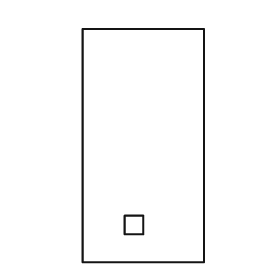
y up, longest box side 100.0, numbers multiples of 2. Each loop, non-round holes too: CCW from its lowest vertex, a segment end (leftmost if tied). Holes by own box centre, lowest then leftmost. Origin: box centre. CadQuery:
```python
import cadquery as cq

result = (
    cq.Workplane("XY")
    .moveTo(-26.0, -50.0)
    .lineTo(26.0, -50.0)
    .lineTo(26.0, 50.0)
    .lineTo(-26.0, 50.0)
    .close()
    .moveTo(-8.0, -38.0)
    .lineTo(0.0, -38.0)
    .lineTo(0.0, -30.0)
    .lineTo(-8.0, -30.0)
    .close()
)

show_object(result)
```